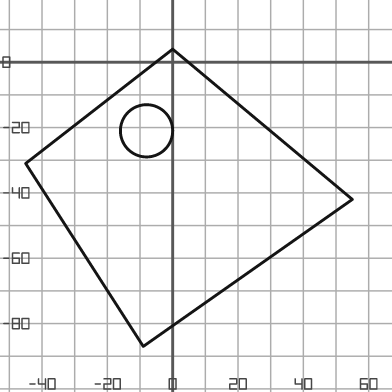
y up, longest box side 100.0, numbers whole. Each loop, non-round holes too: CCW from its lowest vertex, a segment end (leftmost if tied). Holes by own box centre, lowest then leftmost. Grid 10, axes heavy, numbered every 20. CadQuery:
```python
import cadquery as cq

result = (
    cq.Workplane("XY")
    .moveTo(-9.0, -87.0)
    .lineTo(55.0, -42.0)
    .lineTo(0.0, 4.0)
    .lineTo(-45.0, -31.0)
    .close()
    .moveTo(-8.0, -21.0)
    .circle(8.0)
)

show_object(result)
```